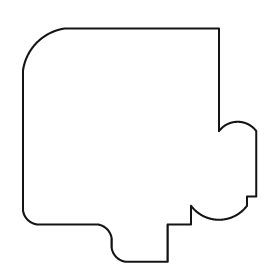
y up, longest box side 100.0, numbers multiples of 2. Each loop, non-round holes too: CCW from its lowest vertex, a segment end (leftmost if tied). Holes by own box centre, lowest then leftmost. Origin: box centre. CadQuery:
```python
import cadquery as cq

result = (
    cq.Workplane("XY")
    .moveTo(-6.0, -50.0)
    .lineTo(12.0, -50.0)
    .lineTo(12.0, -34.0)
    .lineTo(22.0, -34.0)
    .lineTo(22.0, -26.0)
    .threePointArc((34.0, -32.0), (46.0, -26.0))
    .lineTo(46.0, -22.0)
    .lineTo(50.0, -22.0)
    .lineTo(50.0, 6.0)
    .threePointArc((42.0, 10.0), (34.0, 6.0))
    .lineTo(34.0, 50.0)
    .lineTo(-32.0, 50.0)
    .threePointArc((-44.0, 44.0), (-50.0, 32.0))
    .lineTo(-50.0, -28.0)
    .threePointArc((-48.0, -32.0), (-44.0, -34.0))
    .lineTo(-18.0, -34.0)
    .threePointArc((-14.0, -36.0), (-12.0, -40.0))
    .lineTo(-12.0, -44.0)
    .threePointArc((-10.0, -48.0), (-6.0, -50.0))
    .close()
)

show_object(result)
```